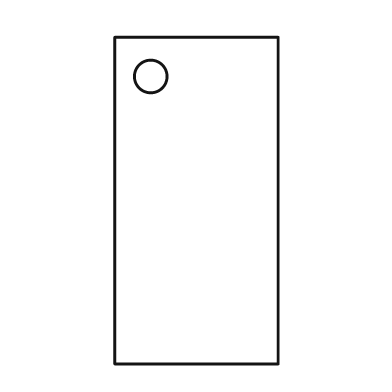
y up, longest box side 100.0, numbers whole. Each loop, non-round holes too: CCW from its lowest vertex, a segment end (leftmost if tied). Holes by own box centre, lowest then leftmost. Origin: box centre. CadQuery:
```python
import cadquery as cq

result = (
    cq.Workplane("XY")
    .moveTo(-25.0, -50.0)
    .lineTo(25.0, -50.0)
    .lineTo(25.0, 50.0)
    .lineTo(-25.0, 50.0)
    .close()
    .moveTo(-14.0, 38.0)
    .circle(5.0)
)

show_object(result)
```